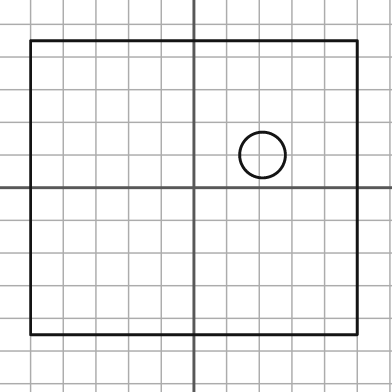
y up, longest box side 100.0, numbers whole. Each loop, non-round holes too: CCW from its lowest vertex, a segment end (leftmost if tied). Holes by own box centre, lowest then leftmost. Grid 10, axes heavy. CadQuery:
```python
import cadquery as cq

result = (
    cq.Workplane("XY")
    .moveTo(-50.0, -45.0)
    .lineTo(50.0, -45.0)
    .lineTo(50.0, 45.0)
    .lineTo(-50.0, 45.0)
    .close()
    .moveTo(21.0, 10.0)
    .circle(7.0)
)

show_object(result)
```